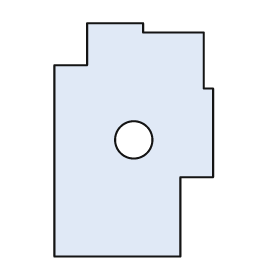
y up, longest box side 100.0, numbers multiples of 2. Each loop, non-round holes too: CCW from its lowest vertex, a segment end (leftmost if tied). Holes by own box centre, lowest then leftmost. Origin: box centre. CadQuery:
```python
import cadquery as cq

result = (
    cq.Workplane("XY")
    .moveTo(-34.0, -50.0)
    .lineTo(20.0, -50.0)
    .lineTo(20.0, -16.0)
    .lineTo(34.0, -16.0)
    .lineTo(34.0, 22.0)
    .lineTo(30.0, 22.0)
    .lineTo(30.0, 46.0)
    .lineTo(4.0, 46.0)
    .lineTo(4.0, 50.0)
    .lineTo(-20.0, 50.0)
    .lineTo(-20.0, 32.0)
    .lineTo(-34.0, 32.0)
    .close()
    .moveTo(0.0, 0.0)
    .circle(8.0)
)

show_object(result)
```